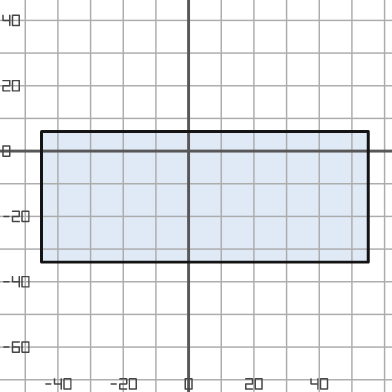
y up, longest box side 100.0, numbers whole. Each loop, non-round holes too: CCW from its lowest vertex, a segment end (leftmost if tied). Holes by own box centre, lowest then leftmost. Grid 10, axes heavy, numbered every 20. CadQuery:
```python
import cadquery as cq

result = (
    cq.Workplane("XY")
    .moveTo(-45.0, -34.0)
    .lineTo(55.0, -34.0)
    .lineTo(55.0, 6.0)
    .lineTo(-45.0, 6.0)
    .close()
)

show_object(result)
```